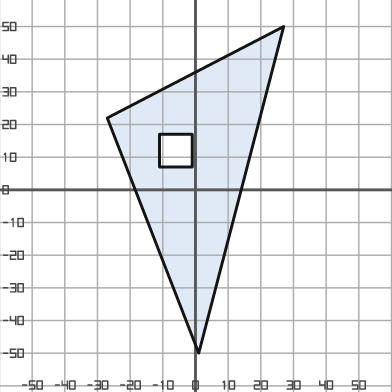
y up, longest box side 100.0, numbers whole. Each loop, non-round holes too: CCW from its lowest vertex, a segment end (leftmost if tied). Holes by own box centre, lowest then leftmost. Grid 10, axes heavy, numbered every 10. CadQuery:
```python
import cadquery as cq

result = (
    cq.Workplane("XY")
    .moveTo(1.0, -50.0)
    .lineTo(27.0, 50.0)
    .lineTo(-27.0, 22.0)
    .close()
    .moveTo(-11.0, 7.0)
    .lineTo(-1.0, 7.0)
    .lineTo(-1.0, 17.0)
    .lineTo(-11.0, 17.0)
    .close()
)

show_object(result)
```